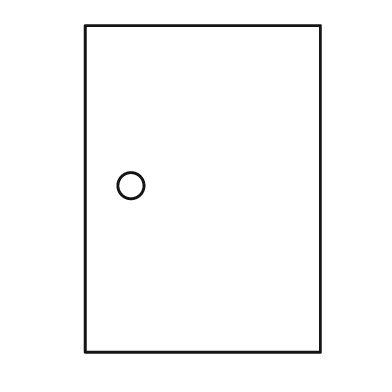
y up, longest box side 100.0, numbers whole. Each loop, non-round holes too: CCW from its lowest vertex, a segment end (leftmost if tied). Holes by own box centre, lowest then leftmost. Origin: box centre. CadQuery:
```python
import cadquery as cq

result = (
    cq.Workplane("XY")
    .moveTo(-36.0, -50.0)
    .lineTo(36.0, -50.0)
    .lineTo(36.0, 50.0)
    .lineTo(-36.0, 50.0)
    .close()
    .moveTo(-22.0, 1.0)
    .circle(4.0)
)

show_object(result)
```